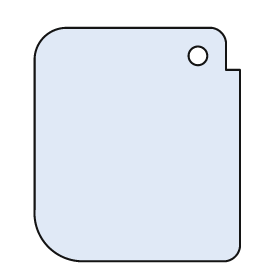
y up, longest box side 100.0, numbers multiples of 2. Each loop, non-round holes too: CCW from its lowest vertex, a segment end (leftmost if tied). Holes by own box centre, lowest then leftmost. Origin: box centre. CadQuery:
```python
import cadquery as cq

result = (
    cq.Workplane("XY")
    .moveTo(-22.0, -50.0)
    .lineTo(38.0, -50.0)
    .threePointArc((42.0, -48.0), (44.0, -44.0))
    .lineTo(44.0, 32.0)
    .lineTo(38.0, 32.0)
    .lineTo(38.0, 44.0)
    .threePointArc((36.0, 48.0), (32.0, 50.0))
    .lineTo(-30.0, 50.0)
    .threePointArc((-40.0, 46.0), (-44.0, 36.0))
    .lineTo(-44.0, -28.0)
    .threePointArc((-38.0, -44.0), (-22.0, -50.0))
    .close()
    .moveTo(26.0, 38.0)
    .circle(4.0)
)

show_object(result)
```